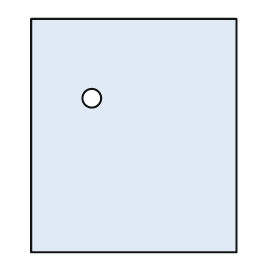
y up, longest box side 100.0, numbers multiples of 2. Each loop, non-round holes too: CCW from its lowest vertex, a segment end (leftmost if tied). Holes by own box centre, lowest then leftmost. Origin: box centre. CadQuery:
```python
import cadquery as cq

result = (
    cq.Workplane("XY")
    .moveTo(-44.0, -50.0)
    .lineTo(44.0, -50.0)
    .lineTo(44.0, 50.0)
    .lineTo(-44.0, 50.0)
    .close()
    .moveTo(-18.0, 16.0)
    .circle(4.0)
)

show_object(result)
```